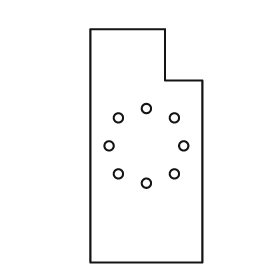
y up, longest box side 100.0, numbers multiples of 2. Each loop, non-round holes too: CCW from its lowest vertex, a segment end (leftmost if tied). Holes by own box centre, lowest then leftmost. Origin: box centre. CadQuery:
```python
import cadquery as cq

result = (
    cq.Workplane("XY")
    .moveTo(-24.0, -50.0)
    .lineTo(24.0, -50.0)
    .lineTo(24.0, 28.0)
    .lineTo(8.0, 28.0)
    .lineTo(8.0, 50.0)
    .lineTo(-24.0, 50.0)
    .close()
    .moveTo(0.0, -16.0)
    .circle(2.0)
    .moveTo(-12.0, -12.0)
    .circle(2.0)
    .moveTo(12.0, -12.0)
    .circle(2.0)
    .moveTo(-16.0, 0.0)
    .circle(2.0)
    .moveTo(16.0, 0.0)
    .circle(2.0)
    .moveTo(-12.0, 12.0)
    .circle(2.0)
    .moveTo(12.0, 12.0)
    .circle(2.0)
    .moveTo(0.0, 16.0)
    .circle(2.0)
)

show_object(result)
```